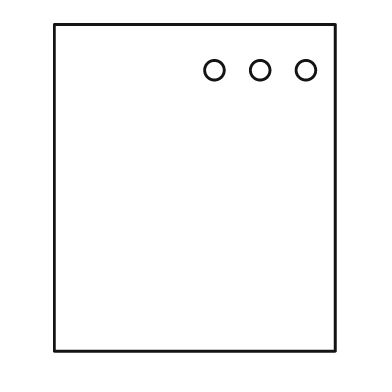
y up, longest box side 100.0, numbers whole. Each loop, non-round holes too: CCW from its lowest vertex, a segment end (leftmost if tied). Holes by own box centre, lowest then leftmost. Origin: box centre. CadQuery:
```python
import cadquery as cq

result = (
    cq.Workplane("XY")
    .moveTo(-43.0, -50.0)
    .lineTo(43.0, -50.0)
    .lineTo(43.0, 50.0)
    .lineTo(-43.0, 50.0)
    .close()
    .moveTo(6.0, 36.0)
    .circle(3.0)
    .moveTo(20.0, 36.0)
    .circle(3.0)
    .moveTo(34.0, 36.0)
    .circle(3.0)
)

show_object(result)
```